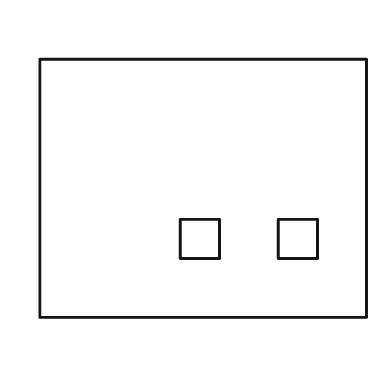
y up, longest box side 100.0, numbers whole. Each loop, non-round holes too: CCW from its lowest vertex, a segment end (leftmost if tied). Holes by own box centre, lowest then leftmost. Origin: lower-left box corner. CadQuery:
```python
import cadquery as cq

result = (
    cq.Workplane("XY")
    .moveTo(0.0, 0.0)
    .lineTo(100.0, 0.0)
    .lineTo(100.0, 79.0)
    .lineTo(0.0, 79.0)
    .close()
    .moveTo(43.0, 18.0)
    .lineTo(55.0, 18.0)
    .lineTo(55.0, 30.0)
    .lineTo(43.0, 30.0)
    .close()
    .moveTo(73.0, 18.0)
    .lineTo(85.0, 18.0)
    .lineTo(85.0, 30.0)
    .lineTo(73.0, 30.0)
    .close()
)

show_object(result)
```